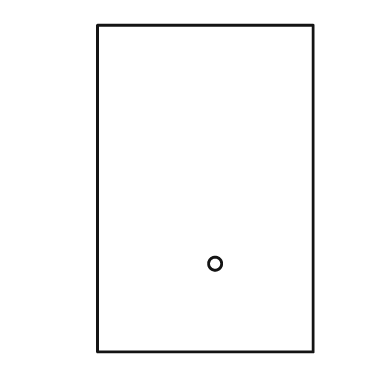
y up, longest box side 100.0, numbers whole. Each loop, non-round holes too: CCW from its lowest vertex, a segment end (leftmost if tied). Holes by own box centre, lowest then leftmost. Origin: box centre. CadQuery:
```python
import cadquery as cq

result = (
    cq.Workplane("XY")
    .moveTo(-33.0, -50.0)
    .lineTo(33.0, -50.0)
    .lineTo(33.0, 50.0)
    .lineTo(-33.0, 50.0)
    .close()
    .moveTo(3.0, -23.0)
    .circle(2.0)
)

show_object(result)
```